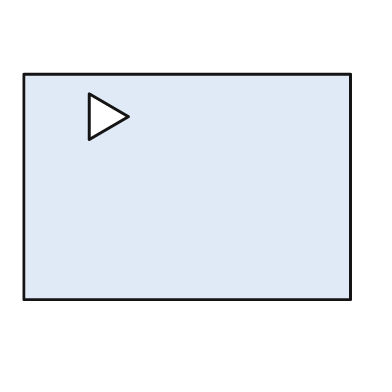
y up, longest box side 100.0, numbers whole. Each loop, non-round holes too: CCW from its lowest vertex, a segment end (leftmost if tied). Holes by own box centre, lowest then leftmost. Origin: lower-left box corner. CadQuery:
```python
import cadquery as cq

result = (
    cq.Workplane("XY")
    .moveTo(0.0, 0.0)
    .lineTo(100.0, 0.0)
    .lineTo(100.0, 69.0)
    .lineTo(0.0, 69.0)
    .close()
    .moveTo(20.0, 49.0)
    .lineTo(32.0, 56.0)
    .lineTo(20.0, 63.0)
    .close()
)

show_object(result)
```